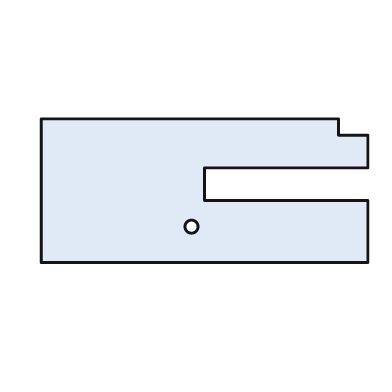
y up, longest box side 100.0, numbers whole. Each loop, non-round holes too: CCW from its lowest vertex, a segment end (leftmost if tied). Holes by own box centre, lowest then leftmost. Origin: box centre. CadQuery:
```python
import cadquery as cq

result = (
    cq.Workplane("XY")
    .moveTo(-50.0, -22.0)
    .lineTo(50.0, -22.0)
    .lineTo(50.0, -3.0)
    .lineTo(0.0, -3.0)
    .lineTo(0.0, 7.0)
    .lineTo(50.0, 7.0)
    .lineTo(50.0, 17.0)
    .lineTo(41.0, 17.0)
    .lineTo(41.0, 22.0)
    .lineTo(-50.0, 22.0)
    .close()
    .moveTo(-4.0, -11.0)
    .circle(2.0)
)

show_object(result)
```